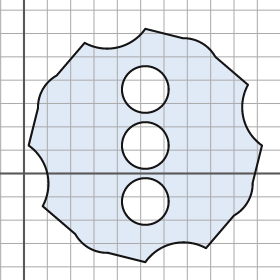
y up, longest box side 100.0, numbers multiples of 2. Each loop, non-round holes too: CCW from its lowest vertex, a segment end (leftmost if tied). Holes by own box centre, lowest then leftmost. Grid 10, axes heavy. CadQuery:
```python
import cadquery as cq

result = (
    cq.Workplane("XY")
    .moveTo(52.0, -38.0)
    .threePointArc((64.0, -30.0), (78.0, -32.0))
    .lineTo(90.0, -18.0)
    .threePointArc((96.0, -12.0), (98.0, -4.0))
    .lineTo(102.0, 12.0)
    .threePointArc((94.0, 24.0), (96.0, 38.0))
    .lineTo(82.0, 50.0)
    .threePointArc((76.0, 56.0), (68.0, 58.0))
    .lineTo(52.0, 62.0)
    .threePointArc((40.0, 54.0), (26.0, 56.0))
    .lineTo(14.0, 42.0)
    .threePointArc((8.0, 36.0), (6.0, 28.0))
    .lineTo(2.0, 12.0)
    .threePointArc((10.0, 0.0), (8.0, -14.0))
    .lineTo(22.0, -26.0)
    .threePointArc((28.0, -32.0), (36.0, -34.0))
    .close()
    .moveTo(52.0, -12.0)
    .circle(10.0)
    .moveTo(52.0, 12.0)
    .circle(10.0)
    .moveTo(52.0, 36.0)
    .circle(10.0)
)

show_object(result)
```